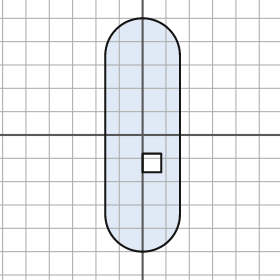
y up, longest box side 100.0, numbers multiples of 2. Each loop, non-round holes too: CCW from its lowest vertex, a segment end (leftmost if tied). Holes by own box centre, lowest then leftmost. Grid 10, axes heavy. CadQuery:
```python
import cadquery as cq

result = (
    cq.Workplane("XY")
    .moveTo(-16.0, -34.0)
    .threePointArc((0.0, -50.0), (16.0, -34.0))
    .lineTo(16.0, 34.0)
    .threePointArc((0.0, 50.0), (-16.0, 34.0))
    .close()
    .moveTo(0.0, -16.0)
    .lineTo(8.0, -16.0)
    .lineTo(8.0, -8.0)
    .lineTo(0.0, -8.0)
    .close()
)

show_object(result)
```